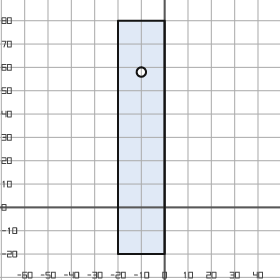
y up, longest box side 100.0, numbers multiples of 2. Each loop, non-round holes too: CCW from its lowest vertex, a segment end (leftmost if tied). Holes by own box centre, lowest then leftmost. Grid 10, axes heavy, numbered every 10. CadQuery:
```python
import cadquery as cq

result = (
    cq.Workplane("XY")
    .moveTo(-20.0, -20.0)
    .lineTo(0.0, -20.0)
    .lineTo(0.0, 80.0)
    .lineTo(-20.0, 80.0)
    .close()
    .moveTo(-10.0, 58.0)
    .circle(2.0)
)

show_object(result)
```